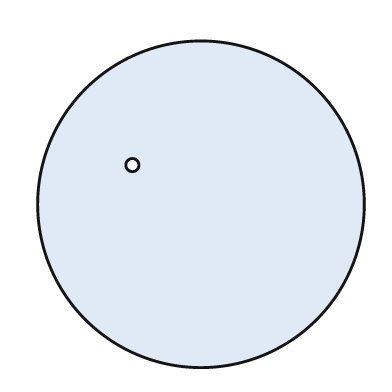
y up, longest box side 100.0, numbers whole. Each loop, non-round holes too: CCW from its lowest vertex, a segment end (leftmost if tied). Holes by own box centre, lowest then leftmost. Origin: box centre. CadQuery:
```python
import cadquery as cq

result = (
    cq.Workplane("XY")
    .moveTo(0.0, 0.0)
    .circle(50.0)
    .moveTo(-21.0, 12.0)
    .circle(2.0)
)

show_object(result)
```